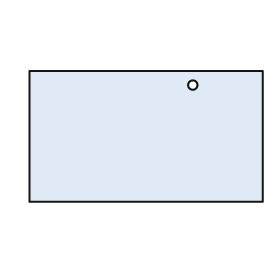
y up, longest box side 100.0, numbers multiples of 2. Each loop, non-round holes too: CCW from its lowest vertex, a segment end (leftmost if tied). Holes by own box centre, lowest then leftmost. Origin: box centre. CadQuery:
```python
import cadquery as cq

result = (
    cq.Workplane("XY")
    .moveTo(-50.0, -28.0)
    .lineTo(50.0, -28.0)
    .lineTo(50.0, 28.0)
    .lineTo(-50.0, 28.0)
    .close()
    .moveTo(20.0, 22.0)
    .circle(2.0)
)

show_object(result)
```